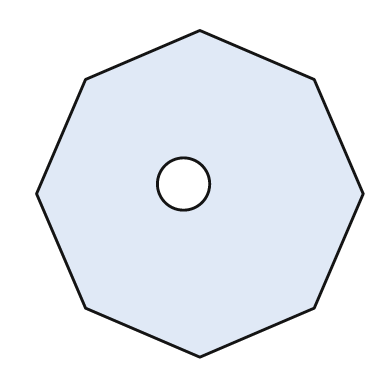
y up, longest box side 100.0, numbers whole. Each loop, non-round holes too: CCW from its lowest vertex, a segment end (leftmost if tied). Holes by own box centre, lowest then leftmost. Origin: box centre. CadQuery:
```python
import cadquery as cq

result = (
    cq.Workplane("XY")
    .moveTo(0.0, -50.0)
    .lineTo(35.0, -35.0)
    .lineTo(50.0, 0.0)
    .lineTo(35.0, 35.0)
    .lineTo(0.0, 50.0)
    .lineTo(-35.0, 35.0)
    .lineTo(-50.0, 0.0)
    .lineTo(-35.0, -35.0)
    .close()
    .moveTo(-5.0, 3.0)
    .circle(8.0)
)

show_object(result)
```